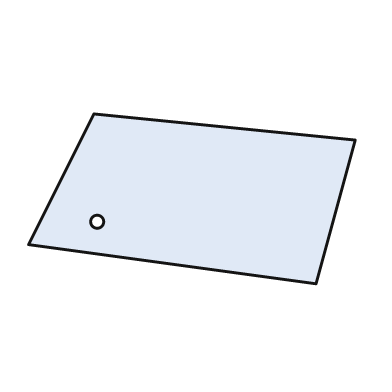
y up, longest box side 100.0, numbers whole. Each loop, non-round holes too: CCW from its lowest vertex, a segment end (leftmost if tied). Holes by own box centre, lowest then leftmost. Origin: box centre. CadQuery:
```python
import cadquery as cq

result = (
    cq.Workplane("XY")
    .moveTo(38.0, -26.0)
    .lineTo(50.0, 18.0)
    .lineTo(-30.0, 26.0)
    .lineTo(-50.0, -14.0)
    .close()
    .moveTo(-29.0, -7.0)
    .circle(2.0)
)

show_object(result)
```